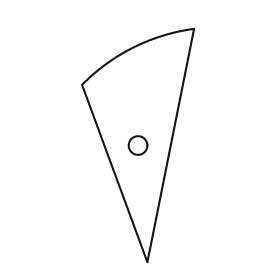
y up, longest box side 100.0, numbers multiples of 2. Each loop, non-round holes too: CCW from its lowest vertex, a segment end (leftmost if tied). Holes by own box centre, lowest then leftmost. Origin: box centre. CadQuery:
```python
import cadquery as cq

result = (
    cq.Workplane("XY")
    .moveTo(4.0, -50.0)
    .lineTo(24.0, 50.0)
    .threePointArc((-2.0, 42.0), (-24.0, 26.0))
    .close()
    .moveTo(0.0, 0.0)
    .circle(4.0)
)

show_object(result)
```